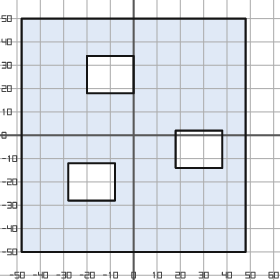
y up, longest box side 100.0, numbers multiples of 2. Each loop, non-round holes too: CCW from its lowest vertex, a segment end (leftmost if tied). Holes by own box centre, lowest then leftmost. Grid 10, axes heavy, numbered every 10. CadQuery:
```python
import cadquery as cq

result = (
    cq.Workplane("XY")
    .moveTo(-48.0, -50.0)
    .lineTo(48.0, -50.0)
    .lineTo(48.0, 50.0)
    .lineTo(-48.0, 50.0)
    .close()
    .moveTo(-28.0, -28.0)
    .lineTo(-8.0, -28.0)
    .lineTo(-8.0, -12.0)
    .lineTo(-28.0, -12.0)
    .close()
    .moveTo(18.0, -14.0)
    .lineTo(38.0, -14.0)
    .lineTo(38.0, 2.0)
    .lineTo(18.0, 2.0)
    .close()
    .moveTo(-20.0, 18.0)
    .lineTo(0.0, 18.0)
    .lineTo(0.0, 34.0)
    .lineTo(-20.0, 34.0)
    .close()
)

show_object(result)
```